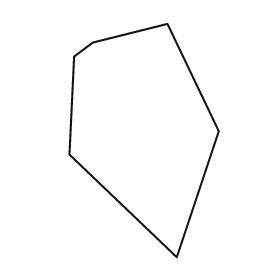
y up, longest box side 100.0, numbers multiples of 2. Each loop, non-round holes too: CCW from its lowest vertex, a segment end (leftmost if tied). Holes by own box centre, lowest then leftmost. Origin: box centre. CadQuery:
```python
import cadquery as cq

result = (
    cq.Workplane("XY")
    .moveTo(14.0, -50.0)
    .lineTo(32.0, 4.0)
    .lineTo(10.0, 50.0)
    .lineTo(-22.0, 42.0)
    .lineTo(-30.0, 36.0)
    .lineTo(-32.0, -6.0)
    .close()
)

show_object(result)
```